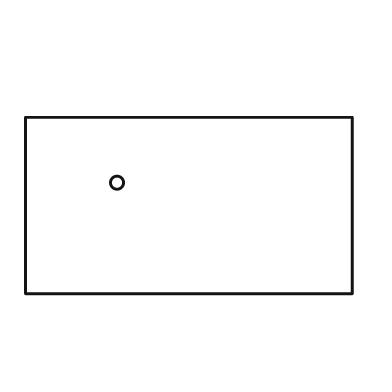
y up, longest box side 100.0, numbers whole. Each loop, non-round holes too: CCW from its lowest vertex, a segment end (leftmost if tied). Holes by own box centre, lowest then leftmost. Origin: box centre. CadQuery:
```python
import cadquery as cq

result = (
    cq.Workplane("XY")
    .moveTo(-50.0, -27.0)
    .lineTo(50.0, -27.0)
    .lineTo(50.0, 27.0)
    .lineTo(-50.0, 27.0)
    .close()
    .moveTo(-22.0, 7.0)
    .circle(2.0)
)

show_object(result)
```